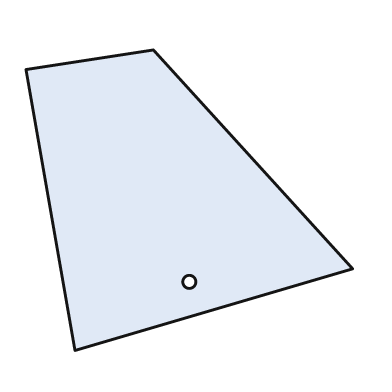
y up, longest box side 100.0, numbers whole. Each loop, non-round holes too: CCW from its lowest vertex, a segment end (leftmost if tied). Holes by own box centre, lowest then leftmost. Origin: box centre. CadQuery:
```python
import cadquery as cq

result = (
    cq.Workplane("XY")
    .moveTo(-35.0, -46.0)
    .lineTo(50.0, -21.0)
    .lineTo(-11.0, 46.0)
    .lineTo(-50.0, 40.0)
    .close()
    .moveTo(0.0, -25.0)
    .circle(2.0)
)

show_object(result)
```